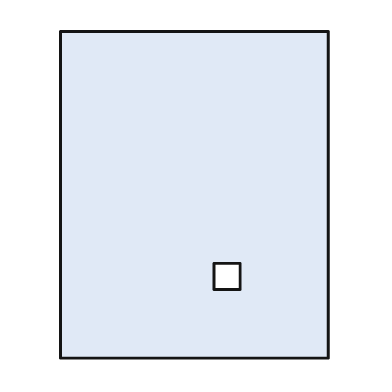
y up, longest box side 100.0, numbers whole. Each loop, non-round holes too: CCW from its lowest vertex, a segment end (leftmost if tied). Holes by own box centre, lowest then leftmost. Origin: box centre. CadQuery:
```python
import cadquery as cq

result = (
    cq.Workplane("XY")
    .moveTo(-41.0, -50.0)
    .lineTo(41.0, -50.0)
    .lineTo(41.0, 50.0)
    .lineTo(-41.0, 50.0)
    .close()
    .moveTo(6.0, -29.0)
    .lineTo(14.0, -29.0)
    .lineTo(14.0, -21.0)
    .lineTo(6.0, -21.0)
    .close()
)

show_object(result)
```